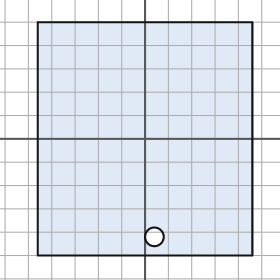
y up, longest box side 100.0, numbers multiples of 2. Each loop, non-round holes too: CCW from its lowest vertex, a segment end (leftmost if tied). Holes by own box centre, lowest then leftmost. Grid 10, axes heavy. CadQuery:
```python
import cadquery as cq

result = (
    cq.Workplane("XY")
    .moveTo(-46.0, -50.0)
    .lineTo(46.0, -50.0)
    .lineTo(46.0, 50.0)
    .lineTo(-46.0, 50.0)
    .close()
    .moveTo(4.0, -42.0)
    .circle(4.0)
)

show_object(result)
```